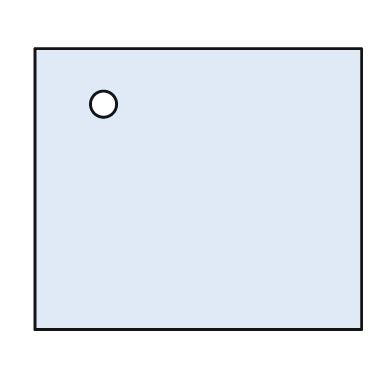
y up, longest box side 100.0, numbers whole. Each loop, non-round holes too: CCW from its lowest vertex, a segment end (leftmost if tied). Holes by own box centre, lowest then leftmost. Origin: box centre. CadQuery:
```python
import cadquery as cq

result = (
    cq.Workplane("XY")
    .moveTo(-50.0, -43.0)
    .lineTo(50.0, -43.0)
    .lineTo(50.0, 43.0)
    .lineTo(-50.0, 43.0)
    .close()
    .moveTo(-29.0, 26.0)
    .circle(4.0)
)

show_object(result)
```